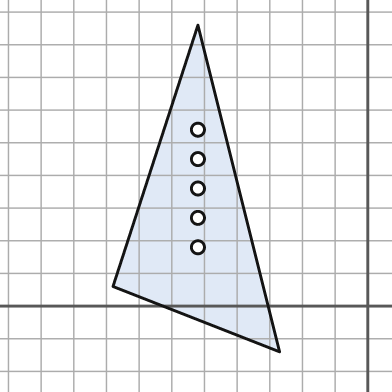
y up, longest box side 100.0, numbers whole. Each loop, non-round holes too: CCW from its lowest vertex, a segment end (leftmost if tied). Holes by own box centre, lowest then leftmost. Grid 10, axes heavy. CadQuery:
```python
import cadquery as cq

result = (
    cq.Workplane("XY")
    .moveTo(-27.0, -14.0)
    .lineTo(-52.0, 86.0)
    .lineTo(-78.0, 6.0)
    .close()
    .moveTo(-52.0, 18.0)
    .circle(2.0)
    .moveTo(-52.0, 27.0)
    .circle(2.0)
    .moveTo(-52.0, 36.0)
    .circle(2.0)
    .moveTo(-52.0, 45.0)
    .circle(2.0)
    .moveTo(-52.0, 54.0)
    .circle(2.0)
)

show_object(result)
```